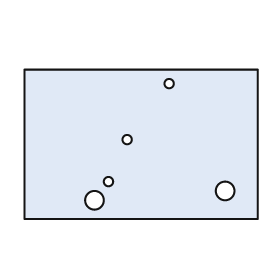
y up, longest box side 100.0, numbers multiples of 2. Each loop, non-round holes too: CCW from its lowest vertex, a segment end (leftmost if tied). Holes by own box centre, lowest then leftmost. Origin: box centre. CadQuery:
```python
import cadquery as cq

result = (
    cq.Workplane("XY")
    .moveTo(-50.0, -32.0)
    .lineTo(50.0, -32.0)
    .lineTo(50.0, 32.0)
    .lineTo(-50.0, 32.0)
    .close()
    .moveTo(-20.0, -24.0)
    .circle(4.0)
    .moveTo(36.0, -20.0)
    .circle(4.0)
    .moveTo(-14.0, -16.0)
    .circle(2.0)
    .moveTo(-6.0, 2.0)
    .circle(2.0)
    .moveTo(12.0, 26.0)
    .circle(2.0)
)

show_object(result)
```